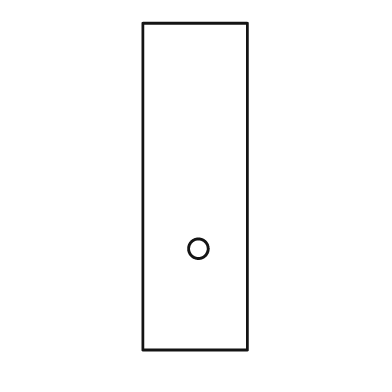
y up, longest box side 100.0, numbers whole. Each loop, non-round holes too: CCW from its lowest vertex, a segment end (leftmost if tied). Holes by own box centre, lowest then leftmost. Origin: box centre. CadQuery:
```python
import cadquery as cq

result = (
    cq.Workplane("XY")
    .moveTo(-16.0, -50.0)
    .lineTo(16.0, -50.0)
    .lineTo(16.0, 50.0)
    .lineTo(-16.0, 50.0)
    .close()
    .moveTo(1.0, -19.0)
    .circle(3.0)
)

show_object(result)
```